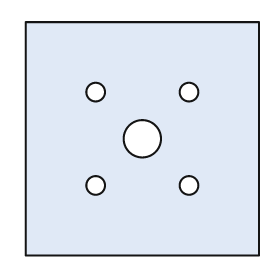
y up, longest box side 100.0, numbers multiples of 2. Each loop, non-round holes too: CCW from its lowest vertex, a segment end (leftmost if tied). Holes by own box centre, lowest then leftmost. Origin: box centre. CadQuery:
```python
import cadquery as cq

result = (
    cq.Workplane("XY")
    .moveTo(-50.0, -50.0)
    .lineTo(50.0, -50.0)
    .lineTo(50.0, 50.0)
    .lineTo(-50.0, 50.0)
    .close()
    .moveTo(-20.0, -20.0)
    .circle(4.0)
    .moveTo(20.0, -20.0)
    .circle(4.0)
    .moveTo(0.0, 0.0)
    .circle(8.0)
    .moveTo(-20.0, 20.0)
    .circle(4.0)
    .moveTo(20.0, 20.0)
    .circle(4.0)
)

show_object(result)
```